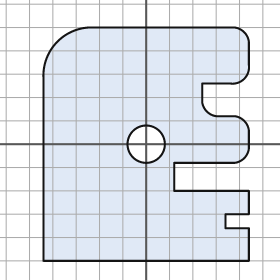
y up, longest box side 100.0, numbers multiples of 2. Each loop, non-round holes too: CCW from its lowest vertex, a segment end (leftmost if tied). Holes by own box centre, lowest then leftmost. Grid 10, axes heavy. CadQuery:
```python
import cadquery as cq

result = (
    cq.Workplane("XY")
    .moveTo(-44.0, -50.0)
    .lineTo(44.0, -50.0)
    .lineTo(44.0, -36.0)
    .lineTo(34.0, -36.0)
    .lineTo(34.0, -30.0)
    .lineTo(44.0, -30.0)
    .lineTo(44.0, -20.0)
    .lineTo(12.0, -20.0)
    .lineTo(12.0, -8.0)
    .lineTo(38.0, -8.0)
    .threePointArc((42.0, -6.0), (44.0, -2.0))
    .lineTo(44.0, 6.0)
    .threePointArc((42.0, 10.0), (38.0, 12.0))
    .lineTo(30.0, 12.0)
    .threePointArc((26.0, 14.0), (24.0, 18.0))
    .lineTo(24.0, 26.0)
    .lineTo(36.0, 26.0)
    .threePointArc((42.0, 28.0), (44.0, 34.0))
    .lineTo(44.0, 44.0)
    .threePointArc((42.0, 48.0), (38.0, 50.0))
    .lineTo(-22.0, 50.0)
    .threePointArc((-38.0, 44.0), (-44.0, 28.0))
    .close()
    .moveTo(0.0, 0.0)
    .circle(8.0)
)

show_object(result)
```